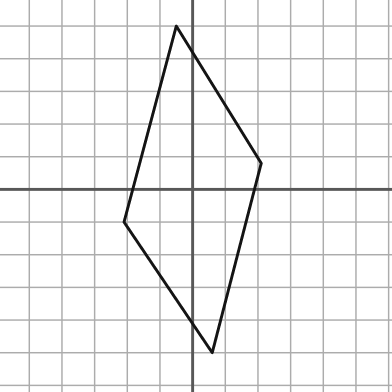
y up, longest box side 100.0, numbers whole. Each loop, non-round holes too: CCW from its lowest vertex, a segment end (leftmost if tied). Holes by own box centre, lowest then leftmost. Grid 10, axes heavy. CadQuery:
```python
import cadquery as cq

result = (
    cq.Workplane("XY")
    .moveTo(6.0, -50.0)
    .lineTo(21.0, 8.0)
    .lineTo(-5.0, 50.0)
    .lineTo(-21.0, -10.0)
    .close()
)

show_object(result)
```